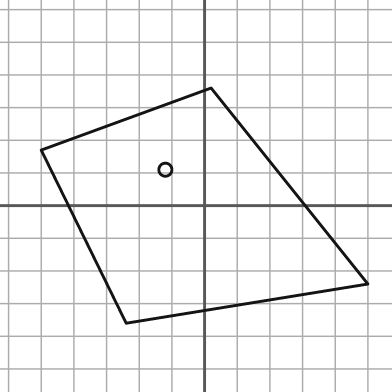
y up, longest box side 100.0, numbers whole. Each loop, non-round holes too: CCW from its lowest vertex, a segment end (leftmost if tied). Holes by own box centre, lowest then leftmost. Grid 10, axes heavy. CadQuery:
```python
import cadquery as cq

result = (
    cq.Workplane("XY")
    .moveTo(-24.0, -36.0)
    .lineTo(50.0, -24.0)
    .lineTo(2.0, 36.0)
    .lineTo(-50.0, 17.0)
    .close()
    .moveTo(-12.0, 11.0)
    .circle(2.0)
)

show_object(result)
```